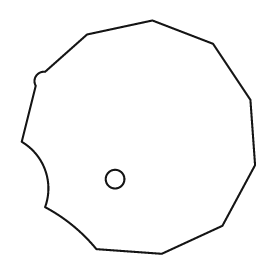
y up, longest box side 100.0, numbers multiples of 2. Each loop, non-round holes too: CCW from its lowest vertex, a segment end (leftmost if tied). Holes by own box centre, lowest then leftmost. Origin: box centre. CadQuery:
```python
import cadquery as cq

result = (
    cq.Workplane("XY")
    .moveTo(10.0, -50.0)
    .lineTo(36.0, -38.0)
    .lineTo(50.0, -12.0)
    .lineTo(48.0, 16.0)
    .lineTo(32.0, 40.0)
    .lineTo(6.0, 50.0)
    .lineTo(-22.0, 44.0)
    .lineTo(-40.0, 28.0)
    .threePointArc((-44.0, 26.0), (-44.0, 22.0))
    .lineTo(-50.0, -2.0)
    .threePointArc((-40.0, -14.0), (-40.0, -30.0))
    .threePointArc((-28.0, -38.0), (-18.0, -48.0))
    .close()
    .moveTo(-10.0, -18.0)
    .circle(4.0)
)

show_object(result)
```